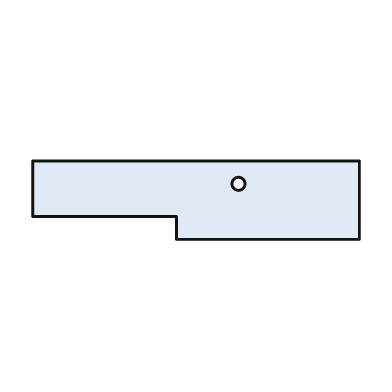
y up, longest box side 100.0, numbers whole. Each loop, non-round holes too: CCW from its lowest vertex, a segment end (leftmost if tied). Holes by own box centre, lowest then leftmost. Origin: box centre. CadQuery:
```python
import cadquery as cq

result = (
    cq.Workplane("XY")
    .moveTo(-6.0, -12.0)
    .lineTo(50.0, -12.0)
    .lineTo(50.0, 12.0)
    .lineTo(-50.0, 12.0)
    .lineTo(-50.0, -5.0)
    .lineTo(-6.0, -5.0)
    .close()
    .moveTo(13.0, 5.0)
    .circle(2.0)
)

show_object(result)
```